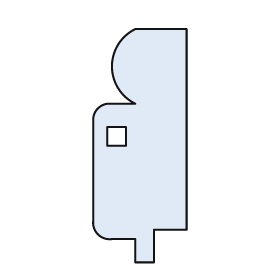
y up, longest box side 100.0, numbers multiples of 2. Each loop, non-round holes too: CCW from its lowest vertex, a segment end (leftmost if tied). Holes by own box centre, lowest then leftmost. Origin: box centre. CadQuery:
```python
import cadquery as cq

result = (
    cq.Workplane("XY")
    .moveTo(-2.0, -50.0)
    .lineTo(6.0, -50.0)
    .lineTo(6.0, -36.0)
    .lineTo(20.0, -36.0)
    .lineTo(20.0, 50.0)
    .lineTo(-2.0, 50.0)
    .threePointArc((-12.0, 34.0), (-2.0, 18.0))
    .lineTo(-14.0, 18.0)
    .threePointArc((-18.0, 16.0), (-20.0, 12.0))
    .lineTo(-20.0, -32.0)
    .threePointArc((-18.0, -38.0), (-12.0, -40.0))
    .lineTo(-2.0, -40.0)
    .close()
    .moveTo(-14.0, 0.0)
    .lineTo(-6.0, 0.0)
    .lineTo(-6.0, 8.0)
    .lineTo(-14.0, 8.0)
    .close()
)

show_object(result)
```